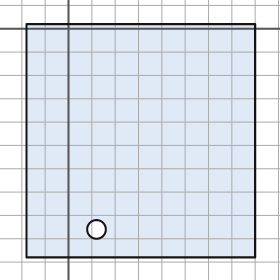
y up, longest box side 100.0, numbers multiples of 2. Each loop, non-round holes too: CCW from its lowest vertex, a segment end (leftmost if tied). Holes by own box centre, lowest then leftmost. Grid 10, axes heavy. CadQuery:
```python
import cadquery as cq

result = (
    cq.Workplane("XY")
    .moveTo(-18.0, -98.0)
    .lineTo(80.0, -98.0)
    .lineTo(80.0, 2.0)
    .lineTo(-18.0, 2.0)
    .close()
    .moveTo(12.0, -86.0)
    .circle(4.0)
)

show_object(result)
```